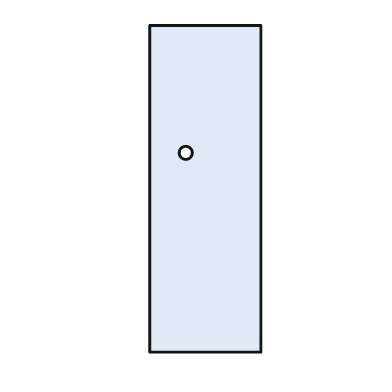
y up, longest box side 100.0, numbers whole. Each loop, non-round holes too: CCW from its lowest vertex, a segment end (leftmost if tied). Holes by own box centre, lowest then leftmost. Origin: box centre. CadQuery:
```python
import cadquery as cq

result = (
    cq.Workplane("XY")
    .moveTo(-17.0, -50.0)
    .lineTo(17.0, -50.0)
    .lineTo(17.0, 50.0)
    .lineTo(-17.0, 50.0)
    .close()
    .moveTo(-6.0, 11.0)
    .circle(2.0)
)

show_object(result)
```